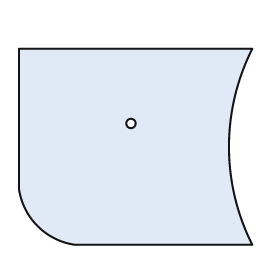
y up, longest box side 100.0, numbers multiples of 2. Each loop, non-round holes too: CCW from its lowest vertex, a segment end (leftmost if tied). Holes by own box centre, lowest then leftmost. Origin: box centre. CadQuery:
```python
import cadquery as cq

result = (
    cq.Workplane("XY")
    .moveTo(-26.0, -42.0)
    .lineTo(50.0, -42.0)
    .threePointArc((40.0, 0.0), (50.0, 42.0))
    .lineTo(-50.0, 42.0)
    .lineTo(-50.0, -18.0)
    .threePointArc((-42.0, -34.0), (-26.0, -42.0))
    .close()
    .moveTo(-2.0, 10.0)
    .circle(2.0)
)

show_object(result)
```